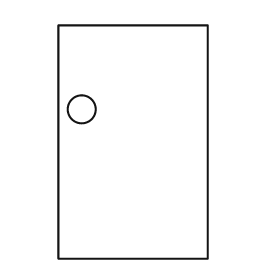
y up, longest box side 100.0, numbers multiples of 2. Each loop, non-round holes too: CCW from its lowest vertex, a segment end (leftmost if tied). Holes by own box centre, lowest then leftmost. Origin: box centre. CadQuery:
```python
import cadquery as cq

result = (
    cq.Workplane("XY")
    .moveTo(-32.0, -50.0)
    .lineTo(32.0, -50.0)
    .lineTo(32.0, 50.0)
    .lineTo(-32.0, 50.0)
    .close()
    .moveTo(-22.0, 14.0)
    .circle(6.0)
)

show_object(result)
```